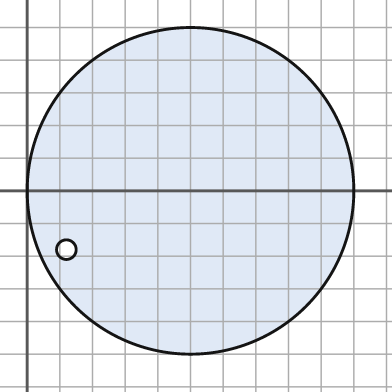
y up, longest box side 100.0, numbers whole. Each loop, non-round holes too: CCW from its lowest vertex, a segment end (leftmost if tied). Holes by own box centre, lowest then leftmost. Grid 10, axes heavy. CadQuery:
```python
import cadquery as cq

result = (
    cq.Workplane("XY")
    .moveTo(50.0, 0.0)
    .circle(50.0)
    .moveTo(12.0, -18.0)
    .circle(3.0)
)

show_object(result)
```